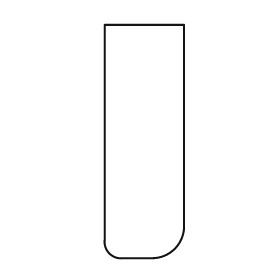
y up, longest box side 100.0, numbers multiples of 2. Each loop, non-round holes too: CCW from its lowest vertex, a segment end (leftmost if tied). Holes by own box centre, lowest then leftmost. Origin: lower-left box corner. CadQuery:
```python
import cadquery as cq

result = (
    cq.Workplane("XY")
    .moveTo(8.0, 0.0)
    .lineTo(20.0, 0.0)
    .threePointArc((30.0, 4.0), (34.0, 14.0))
    .lineTo(34.0, 100.0)
    .lineTo(0.0, 100.0)
    .lineTo(0.0, 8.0)
    .threePointArc((2.0, 2.0), (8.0, 0.0))
    .close()
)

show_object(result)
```